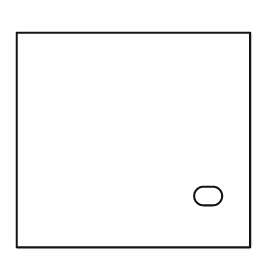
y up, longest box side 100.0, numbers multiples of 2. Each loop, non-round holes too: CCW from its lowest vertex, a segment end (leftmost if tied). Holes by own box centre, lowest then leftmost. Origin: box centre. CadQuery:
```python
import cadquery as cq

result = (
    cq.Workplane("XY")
    .moveTo(-50.0, -46.0)
    .lineTo(50.0, -46.0)
    .lineTo(50.0, 46.0)
    .lineTo(-50.0, 46.0)
    .close()
    .moveTo(30.0, -28.0)
    .lineTo(34.0, -28.0)
    .threePointArc((38.0, -24.0), (34.0, -20.0))
    .lineTo(30.0, -20.0)
    .threePointArc((26.0, -24.0), (30.0, -28.0))
    .close()
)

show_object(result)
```